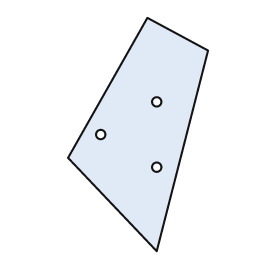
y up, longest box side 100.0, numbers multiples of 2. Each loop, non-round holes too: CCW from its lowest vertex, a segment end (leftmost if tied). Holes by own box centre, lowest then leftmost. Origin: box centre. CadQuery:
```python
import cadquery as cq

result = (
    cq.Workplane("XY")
    .moveTo(8.0, -50.0)
    .lineTo(30.0, 36.0)
    .lineTo(4.0, 50.0)
    .lineTo(-30.0, -10.0)
    .close()
    .moveTo(8.0, -14.0)
    .circle(2.0)
    .moveTo(-16.0, 0.0)
    .circle(2.0)
    .moveTo(8.0, 14.0)
    .circle(2.0)
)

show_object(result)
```